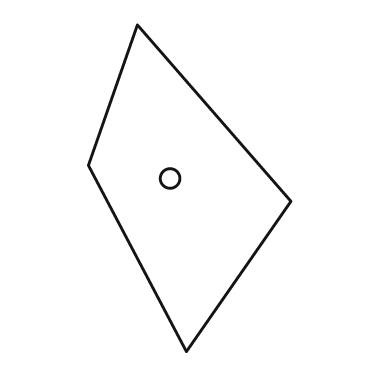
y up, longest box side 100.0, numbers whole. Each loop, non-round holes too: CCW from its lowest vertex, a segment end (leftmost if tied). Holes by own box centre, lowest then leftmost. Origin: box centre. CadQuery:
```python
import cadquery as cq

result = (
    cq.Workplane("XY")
    .moveTo(-1.0, -50.0)
    .lineTo(31.0, -4.0)
    .lineTo(-16.0, 50.0)
    .lineTo(-31.0, 7.0)
    .close()
    .moveTo(-6.0, 3.0)
    .circle(3.0)
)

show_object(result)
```